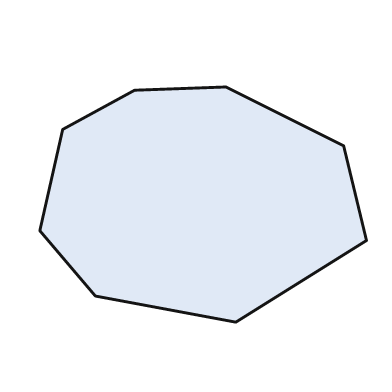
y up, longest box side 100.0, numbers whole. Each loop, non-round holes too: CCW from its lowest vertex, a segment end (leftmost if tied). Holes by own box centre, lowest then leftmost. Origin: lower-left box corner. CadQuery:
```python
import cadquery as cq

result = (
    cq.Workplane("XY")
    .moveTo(60.0, 0.0)
    .lineTo(100.0, 25.0)
    .lineTo(93.0, 54.0)
    .lineTo(57.0, 72.0)
    .lineTo(29.0, 71.0)
    .lineTo(7.0, 59.0)
    .lineTo(0.0, 28.0)
    .lineTo(17.0, 8.0)
    .close()
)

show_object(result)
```